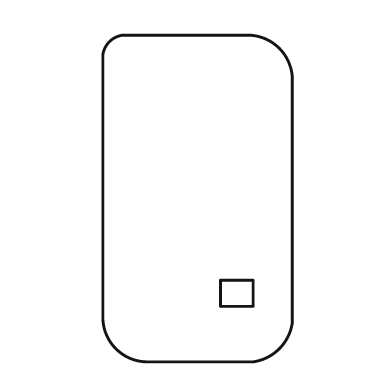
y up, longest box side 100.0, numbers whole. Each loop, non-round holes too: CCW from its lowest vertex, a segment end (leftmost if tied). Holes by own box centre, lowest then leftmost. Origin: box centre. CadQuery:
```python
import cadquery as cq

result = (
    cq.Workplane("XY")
    .moveTo(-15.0, -50.0)
    .lineTo(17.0, -50.0)
    .threePointArc((25.0, -46.0), (29.0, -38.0))
    .lineTo(29.0, 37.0)
    .threePointArc((25.0, 46.0), (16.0, 50.0))
    .lineTo(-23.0, 50.0)
    .threePointArc((-27.0, 48.0), (-29.0, 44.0))
    .lineTo(-29.0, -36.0)
    .threePointArc((-25.0, -46.0), (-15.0, -50.0))
    .close()
    .moveTo(7.0, -33.0)
    .lineTo(17.0, -33.0)
    .lineTo(17.0, -25.0)
    .lineTo(7.0, -25.0)
    .close()
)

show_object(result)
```